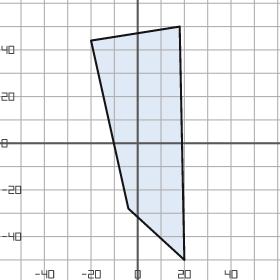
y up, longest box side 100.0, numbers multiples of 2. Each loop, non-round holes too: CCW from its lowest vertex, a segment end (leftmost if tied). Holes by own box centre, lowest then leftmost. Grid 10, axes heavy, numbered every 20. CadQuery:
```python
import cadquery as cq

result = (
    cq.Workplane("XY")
    .moveTo(20.0, -50.0)
    .lineTo(18.0, 50.0)
    .lineTo(-20.0, 44.0)
    .lineTo(-4.0, -28.0)
    .close()
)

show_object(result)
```